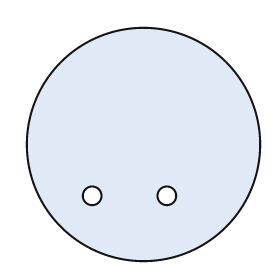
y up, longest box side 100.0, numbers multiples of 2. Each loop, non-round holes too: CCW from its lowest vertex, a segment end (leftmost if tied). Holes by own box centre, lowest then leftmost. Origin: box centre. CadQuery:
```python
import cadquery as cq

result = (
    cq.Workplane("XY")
    .moveTo(0.0, 0.0)
    .circle(50.0)
    .moveTo(-22.0, -22.0)
    .circle(4.0)
    .moveTo(10.0, -22.0)
    .circle(4.0)
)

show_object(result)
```